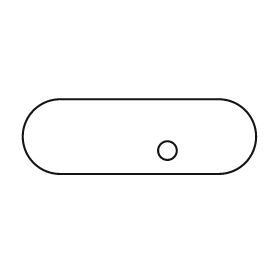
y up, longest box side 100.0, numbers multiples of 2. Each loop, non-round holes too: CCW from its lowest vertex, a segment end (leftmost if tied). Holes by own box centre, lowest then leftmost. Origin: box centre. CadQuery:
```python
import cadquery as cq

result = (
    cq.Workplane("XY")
    .moveTo(-34.0, -16.0)
    .lineTo(34.0, -16.0)
    .threePointArc((50.0, 0.0), (34.0, 16.0))
    .lineTo(-34.0, 16.0)
    .threePointArc((-50.0, 0.0), (-34.0, -16.0))
    .close()
    .moveTo(12.0, -6.0)
    .circle(4.0)
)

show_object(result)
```